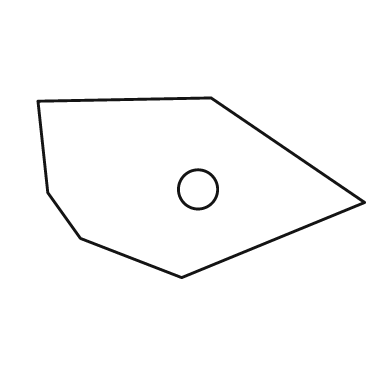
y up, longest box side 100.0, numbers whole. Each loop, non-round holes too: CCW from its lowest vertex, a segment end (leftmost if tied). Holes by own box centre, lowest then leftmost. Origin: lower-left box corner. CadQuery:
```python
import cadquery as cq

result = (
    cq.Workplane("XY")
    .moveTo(44.0, 0.0)
    .lineTo(100.0, 23.0)
    .lineTo(53.0, 55.0)
    .lineTo(0.0, 54.0)
    .lineTo(3.0, 26.0)
    .lineTo(13.0, 12.0)
    .close()
    .moveTo(49.0, 27.0)
    .circle(6.0)
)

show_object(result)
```